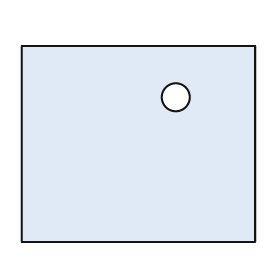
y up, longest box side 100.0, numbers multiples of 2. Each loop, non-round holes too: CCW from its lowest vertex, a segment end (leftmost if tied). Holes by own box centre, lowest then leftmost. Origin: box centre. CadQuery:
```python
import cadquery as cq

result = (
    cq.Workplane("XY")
    .moveTo(-50.0, -42.0)
    .lineTo(50.0, -42.0)
    .lineTo(50.0, 42.0)
    .lineTo(-50.0, 42.0)
    .close()
    .moveTo(16.0, 20.0)
    .circle(6.0)
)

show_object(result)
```